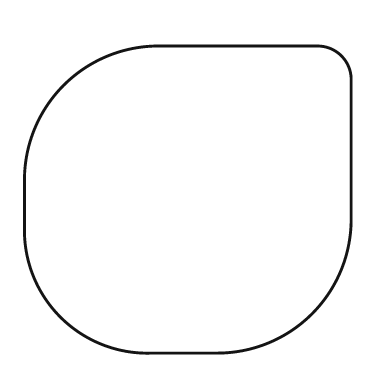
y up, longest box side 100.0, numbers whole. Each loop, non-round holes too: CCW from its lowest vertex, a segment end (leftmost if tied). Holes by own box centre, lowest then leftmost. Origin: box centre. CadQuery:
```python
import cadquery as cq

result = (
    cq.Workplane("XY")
    .moveTo(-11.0, -47.0)
    .lineTo(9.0, -47.0)
    .threePointArc((38.0, -35.0), (50.0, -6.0))
    .lineTo(50.0, 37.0)
    .threePointArc((47.0, 44.0), (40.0, 47.0))
    .lineTo(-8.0, 47.0)
    .threePointArc((-38.0, 35.0), (-50.0, 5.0))
    .lineTo(-50.0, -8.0)
    .threePointArc((-39.0, -36.0), (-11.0, -47.0))
    .close()
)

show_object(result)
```